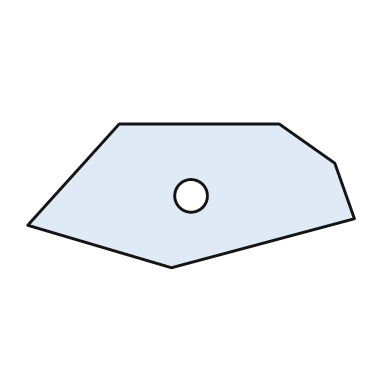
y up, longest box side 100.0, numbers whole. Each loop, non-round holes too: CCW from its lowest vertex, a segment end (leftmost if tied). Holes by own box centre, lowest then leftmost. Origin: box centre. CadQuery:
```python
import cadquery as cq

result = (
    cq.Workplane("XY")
    .moveTo(-6.0, -22.0)
    .lineTo(50.0, -7.0)
    .lineTo(44.0, 10.0)
    .lineTo(27.0, 22.0)
    .lineTo(-22.0, 22.0)
    .lineTo(-50.0, -9.0)
    .close()
    .moveTo(0.0, 0.0)
    .circle(5.0)
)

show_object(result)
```